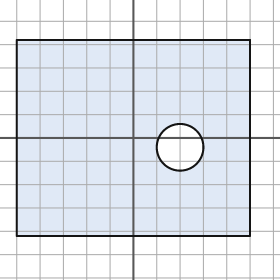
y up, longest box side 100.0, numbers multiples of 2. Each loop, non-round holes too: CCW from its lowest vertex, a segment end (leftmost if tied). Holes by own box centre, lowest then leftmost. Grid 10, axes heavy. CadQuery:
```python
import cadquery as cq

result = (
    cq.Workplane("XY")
    .moveTo(-50.0, -42.0)
    .lineTo(50.0, -42.0)
    .lineTo(50.0, 42.0)
    .lineTo(-50.0, 42.0)
    .close()
    .moveTo(20.0, -4.0)
    .circle(10.0)
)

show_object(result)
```